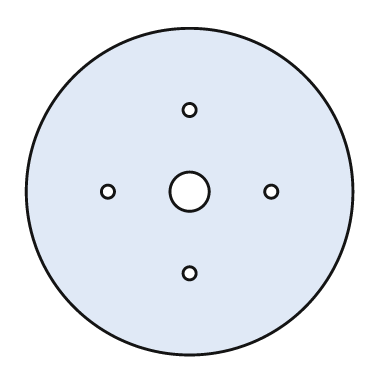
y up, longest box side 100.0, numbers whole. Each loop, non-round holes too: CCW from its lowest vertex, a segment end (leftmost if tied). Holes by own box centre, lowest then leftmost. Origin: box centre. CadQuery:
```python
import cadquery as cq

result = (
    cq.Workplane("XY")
    .moveTo(0.0, 0.0)
    .circle(50.0)
    .moveTo(0.0, -25.0)
    .circle(2.0)
    .moveTo(-25.0, 0.0)
    .circle(2.0)
    .moveTo(0.0, 0.0)
    .circle(6.0)
    .moveTo(25.0, 0.0)
    .circle(2.0)
    .moveTo(0.0, 25.0)
    .circle(2.0)
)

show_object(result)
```